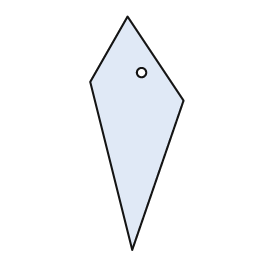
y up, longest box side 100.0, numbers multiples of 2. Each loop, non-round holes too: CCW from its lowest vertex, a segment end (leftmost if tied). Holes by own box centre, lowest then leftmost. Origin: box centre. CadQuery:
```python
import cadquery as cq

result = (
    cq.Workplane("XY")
    .moveTo(-2.0, -50.0)
    .lineTo(20.0, 14.0)
    .lineTo(-4.0, 50.0)
    .lineTo(-20.0, 22.0)
    .close()
    .moveTo(2.0, 26.0)
    .circle(2.0)
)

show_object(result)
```